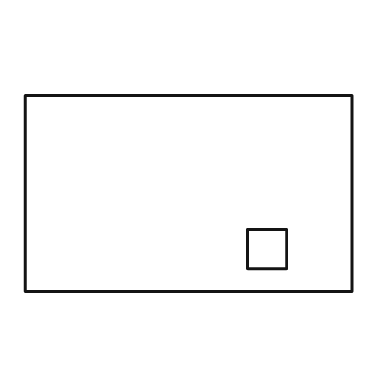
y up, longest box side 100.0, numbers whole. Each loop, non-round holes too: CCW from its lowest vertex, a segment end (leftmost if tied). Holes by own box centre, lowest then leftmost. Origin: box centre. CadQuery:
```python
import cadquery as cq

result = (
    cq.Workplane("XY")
    .moveTo(-50.0, -30.0)
    .lineTo(50.0, -30.0)
    .lineTo(50.0, 30.0)
    .lineTo(-50.0, 30.0)
    .close()
    .moveTo(18.0, -23.0)
    .lineTo(30.0, -23.0)
    .lineTo(30.0, -11.0)
    .lineTo(18.0, -11.0)
    .close()
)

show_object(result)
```